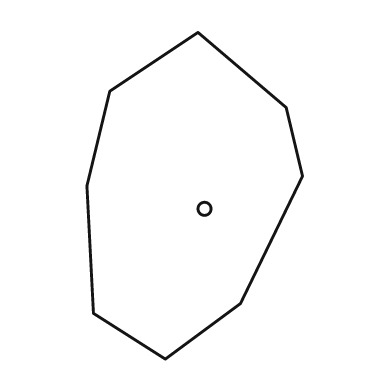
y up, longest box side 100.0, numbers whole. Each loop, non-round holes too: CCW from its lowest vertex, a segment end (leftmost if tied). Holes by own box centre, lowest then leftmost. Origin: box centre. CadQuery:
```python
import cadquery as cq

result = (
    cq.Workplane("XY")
    .moveTo(-9.0, -50.0)
    .lineTo(14.0, -33.0)
    .lineTo(33.0, 6.0)
    .lineTo(28.0, 27.0)
    .lineTo(1.0, 50.0)
    .lineTo(-26.0, 32.0)
    .lineTo(-33.0, 3.0)
    .lineTo(-31.0, -36.0)
    .close()
    .moveTo(3.0, -4.0)
    .circle(2.0)
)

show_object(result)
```